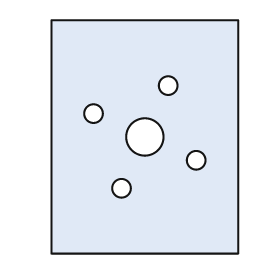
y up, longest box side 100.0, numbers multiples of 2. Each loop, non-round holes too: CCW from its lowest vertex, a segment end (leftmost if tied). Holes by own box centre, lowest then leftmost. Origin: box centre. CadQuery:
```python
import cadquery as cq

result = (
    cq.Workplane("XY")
    .moveTo(-40.0, -50.0)
    .lineTo(40.0, -50.0)
    .lineTo(40.0, 50.0)
    .lineTo(-40.0, 50.0)
    .close()
    .moveTo(-10.0, -22.0)
    .circle(4.0)
    .moveTo(22.0, -10.0)
    .circle(4.0)
    .moveTo(0.0, 0.0)
    .circle(8.0)
    .moveTo(-22.0, 10.0)
    .circle(4.0)
    .moveTo(10.0, 22.0)
    .circle(4.0)
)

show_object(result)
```